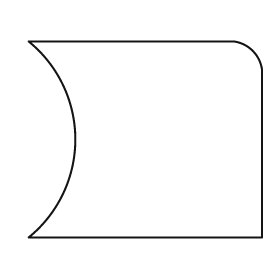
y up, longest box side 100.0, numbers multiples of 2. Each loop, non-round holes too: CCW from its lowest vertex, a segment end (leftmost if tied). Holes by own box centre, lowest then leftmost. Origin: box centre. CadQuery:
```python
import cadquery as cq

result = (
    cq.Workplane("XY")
    .moveTo(-50.0, -42.0)
    .lineTo(50.0, -42.0)
    .lineTo(50.0, 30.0)
    .threePointArc((46.0, 38.0), (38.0, 42.0))
    .lineTo(-50.0, 42.0)
    .threePointArc((-30.0, 0.0), (-50.0, -42.0))
    .close()
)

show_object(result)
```